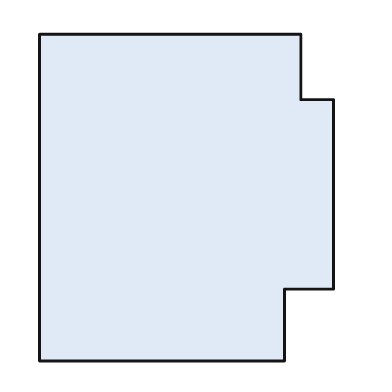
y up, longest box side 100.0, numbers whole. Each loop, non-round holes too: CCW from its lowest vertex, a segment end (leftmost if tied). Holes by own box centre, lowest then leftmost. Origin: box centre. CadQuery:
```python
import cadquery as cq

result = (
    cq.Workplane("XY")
    .moveTo(-45.0, -50.0)
    .lineTo(30.0, -50.0)
    .lineTo(30.0, -28.0)
    .lineTo(45.0, -28.0)
    .lineTo(45.0, 30.0)
    .lineTo(35.0, 30.0)
    .lineTo(35.0, 50.0)
    .lineTo(-45.0, 50.0)
    .close()
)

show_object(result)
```